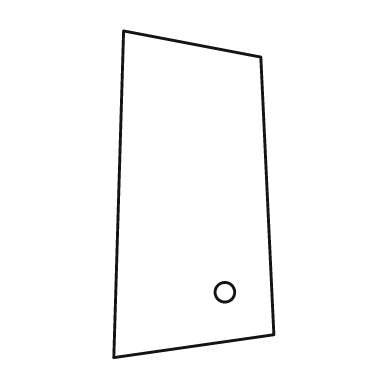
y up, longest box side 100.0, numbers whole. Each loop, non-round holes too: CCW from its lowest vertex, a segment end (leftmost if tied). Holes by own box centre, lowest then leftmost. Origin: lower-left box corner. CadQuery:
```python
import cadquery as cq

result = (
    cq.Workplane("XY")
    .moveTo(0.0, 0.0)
    .lineTo(49.0, 7.0)
    .lineTo(45.0, 92.0)
    .lineTo(3.0, 100.0)
    .close()
    .moveTo(34.0, 20.0)
    .circle(3.0)
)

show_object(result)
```